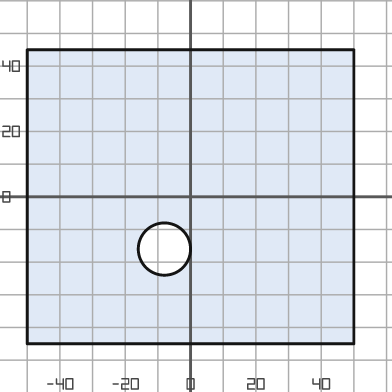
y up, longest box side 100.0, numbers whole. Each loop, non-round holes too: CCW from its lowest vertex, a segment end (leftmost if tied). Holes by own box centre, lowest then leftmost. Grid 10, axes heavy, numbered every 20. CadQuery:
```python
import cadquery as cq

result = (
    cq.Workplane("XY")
    .moveTo(-50.0, -45.0)
    .lineTo(50.0, -45.0)
    .lineTo(50.0, 45.0)
    .lineTo(-50.0, 45.0)
    .close()
    .moveTo(-8.0, -16.0)
    .circle(8.0)
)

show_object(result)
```